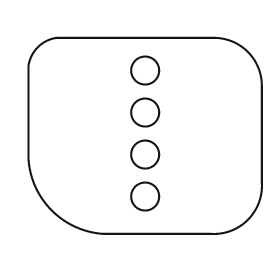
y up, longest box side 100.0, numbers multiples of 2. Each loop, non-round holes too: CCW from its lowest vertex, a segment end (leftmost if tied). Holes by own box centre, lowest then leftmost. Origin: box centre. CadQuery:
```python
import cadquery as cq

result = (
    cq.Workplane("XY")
    .moveTo(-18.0, -42.0)
    .lineTo(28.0, -42.0)
    .threePointArc((44.0, -36.0), (50.0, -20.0))
    .lineTo(50.0, 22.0)
    .threePointArc((44.0, 36.0), (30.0, 42.0))
    .lineTo(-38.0, 42.0)
    .threePointArc((-46.0, 38.0), (-50.0, 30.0))
    .lineTo(-50.0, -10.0)
    .threePointArc((-40.0, -32.0), (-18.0, -42.0))
    .close()
    .moveTo(0.0, -26.0)
    .circle(6.0)
    .moveTo(0.0, -8.0)
    .circle(6.0)
    .moveTo(0.0, 10.0)
    .circle(6.0)
    .moveTo(0.0, 28.0)
    .circle(6.0)
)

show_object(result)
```